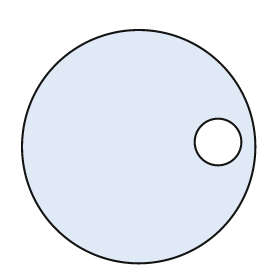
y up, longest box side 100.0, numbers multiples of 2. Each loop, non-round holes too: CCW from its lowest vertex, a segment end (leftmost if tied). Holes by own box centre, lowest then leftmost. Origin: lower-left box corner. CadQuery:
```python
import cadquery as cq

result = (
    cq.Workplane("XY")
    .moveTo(50.0, 50.0)
    .circle(50.0)
    .moveTo(84.0, 52.0)
    .circle(10.0)
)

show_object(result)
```